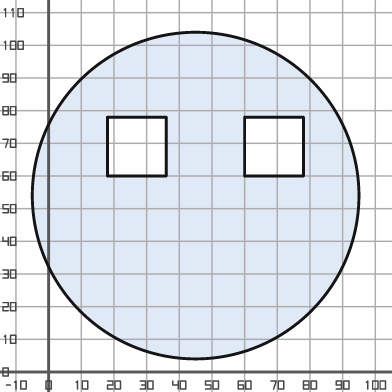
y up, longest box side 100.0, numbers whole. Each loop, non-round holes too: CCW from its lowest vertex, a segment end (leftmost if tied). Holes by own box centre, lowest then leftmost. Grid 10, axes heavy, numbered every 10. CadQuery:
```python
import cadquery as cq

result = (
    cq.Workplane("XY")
    .moveTo(45.0, 54.0)
    .circle(50.0)
    .moveTo(18.0, 60.0)
    .lineTo(36.0, 60.0)
    .lineTo(36.0, 78.0)
    .lineTo(18.0, 78.0)
    .close()
    .moveTo(60.0, 60.0)
    .lineTo(78.0, 60.0)
    .lineTo(78.0, 78.0)
    .lineTo(60.0, 78.0)
    .close()
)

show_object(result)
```